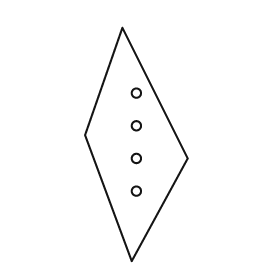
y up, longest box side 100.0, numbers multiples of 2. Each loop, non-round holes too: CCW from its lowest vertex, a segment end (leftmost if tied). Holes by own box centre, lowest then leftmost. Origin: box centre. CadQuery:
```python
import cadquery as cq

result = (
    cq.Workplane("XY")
    .moveTo(-2.0, -50.0)
    .lineTo(22.0, -6.0)
    .lineTo(-6.0, 50.0)
    .lineTo(-22.0, 4.0)
    .close()
    .moveTo(0.0, -20.0)
    .circle(2.0)
    .moveTo(0.0, -6.0)
    .circle(2.0)
    .moveTo(0.0, 8.0)
    .circle(2.0)
    .moveTo(0.0, 22.0)
    .circle(2.0)
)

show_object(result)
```